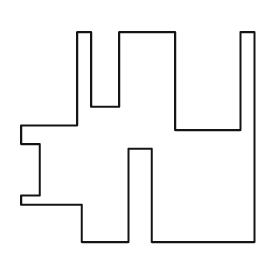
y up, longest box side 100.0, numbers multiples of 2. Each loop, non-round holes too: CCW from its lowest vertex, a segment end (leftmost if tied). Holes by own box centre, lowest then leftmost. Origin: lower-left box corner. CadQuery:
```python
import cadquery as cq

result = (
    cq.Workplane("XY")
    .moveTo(26.0, 0.0)
    .lineTo(46.0, 0.0)
    .lineTo(46.0, 40.0)
    .lineTo(56.0, 40.0)
    .lineTo(56.0, 0.0)
    .lineTo(100.0, 0.0)
    .lineTo(100.0, 90.0)
    .lineTo(94.0, 90.0)
    .lineTo(94.0, 48.0)
    .lineTo(66.0, 48.0)
    .lineTo(66.0, 90.0)
    .lineTo(42.0, 90.0)
    .lineTo(42.0, 58.0)
    .lineTo(30.0, 58.0)
    .lineTo(30.0, 90.0)
    .lineTo(24.0, 90.0)
    .lineTo(24.0, 50.0)
    .lineTo(0.0, 50.0)
    .lineTo(0.0, 42.0)
    .lineTo(8.0, 42.0)
    .lineTo(8.0, 20.0)
    .lineTo(0.0, 20.0)
    .lineTo(0.0, 16.0)
    .lineTo(26.0, 16.0)
    .close()
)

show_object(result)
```